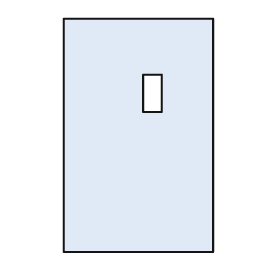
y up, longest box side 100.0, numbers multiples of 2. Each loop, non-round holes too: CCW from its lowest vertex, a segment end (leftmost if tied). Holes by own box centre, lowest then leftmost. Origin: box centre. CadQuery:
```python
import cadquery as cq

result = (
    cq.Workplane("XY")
    .moveTo(-32.0, -50.0)
    .lineTo(32.0, -50.0)
    .lineTo(32.0, 50.0)
    .lineTo(-32.0, 50.0)
    .close()
    .moveTo(2.0, 10.0)
    .lineTo(10.0, 10.0)
    .lineTo(10.0, 26.0)
    .lineTo(2.0, 26.0)
    .close()
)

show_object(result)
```